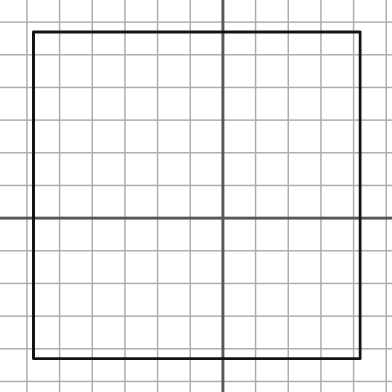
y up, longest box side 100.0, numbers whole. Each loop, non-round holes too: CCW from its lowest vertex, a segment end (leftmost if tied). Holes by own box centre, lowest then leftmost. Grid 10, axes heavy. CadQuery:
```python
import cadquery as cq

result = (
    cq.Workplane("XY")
    .moveTo(-58.0, -43.0)
    .lineTo(42.0, -43.0)
    .lineTo(42.0, 57.0)
    .lineTo(-58.0, 57.0)
    .close()
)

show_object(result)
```